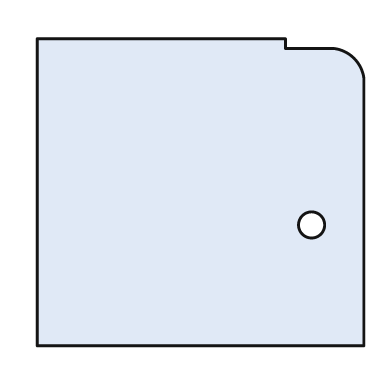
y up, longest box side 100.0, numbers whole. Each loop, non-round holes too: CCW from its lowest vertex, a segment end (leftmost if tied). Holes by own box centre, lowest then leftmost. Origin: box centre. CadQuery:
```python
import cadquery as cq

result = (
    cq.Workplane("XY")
    .moveTo(-50.0, -47.0)
    .lineTo(50.0, -47.0)
    .lineTo(50.0, 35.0)
    .threePointArc((47.0, 41.0), (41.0, 44.0))
    .lineTo(26.0, 44.0)
    .lineTo(26.0, 47.0)
    .lineTo(-50.0, 47.0)
    .close()
    .moveTo(34.0, -10.0)
    .circle(4.0)
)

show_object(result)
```